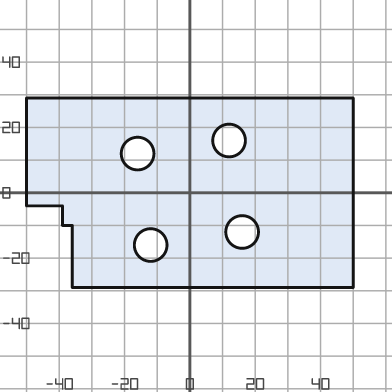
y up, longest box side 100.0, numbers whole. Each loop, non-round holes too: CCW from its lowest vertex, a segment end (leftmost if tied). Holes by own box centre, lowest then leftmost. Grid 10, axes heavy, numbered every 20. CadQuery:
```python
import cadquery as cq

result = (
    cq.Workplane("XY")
    .moveTo(-36.0, -29.0)
    .lineTo(50.0, -29.0)
    .lineTo(50.0, 29.0)
    .lineTo(-50.0, 29.0)
    .lineTo(-50.0, -4.0)
    .lineTo(-39.0, -4.0)
    .lineTo(-39.0, -10.0)
    .lineTo(-36.0, -10.0)
    .close()
    .moveTo(-12.0, -16.0)
    .circle(5.0)
    .moveTo(16.0, -12.0)
    .circle(5.0)
    .moveTo(-16.0, 12.0)
    .circle(5.0)
    .moveTo(12.0, 16.0)
    .circle(5.0)
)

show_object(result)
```